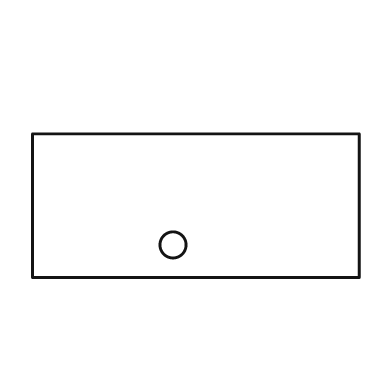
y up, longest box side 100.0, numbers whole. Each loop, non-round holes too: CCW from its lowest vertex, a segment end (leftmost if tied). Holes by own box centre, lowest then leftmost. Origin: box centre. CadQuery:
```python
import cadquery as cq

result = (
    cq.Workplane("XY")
    .moveTo(-50.0, -22.0)
    .lineTo(50.0, -22.0)
    .lineTo(50.0, 22.0)
    .lineTo(-50.0, 22.0)
    .close()
    .moveTo(-7.0, -12.0)
    .circle(4.0)
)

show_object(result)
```